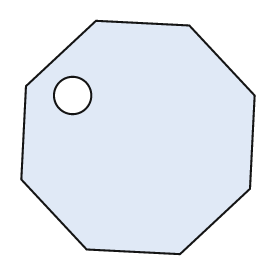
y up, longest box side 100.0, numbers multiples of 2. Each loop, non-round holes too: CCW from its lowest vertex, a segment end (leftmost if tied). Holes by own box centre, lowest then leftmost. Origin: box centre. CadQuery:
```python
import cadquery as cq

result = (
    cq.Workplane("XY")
    .moveTo(18.0, -50.0)
    .lineTo(48.0, -22.0)
    .lineTo(50.0, 18.0)
    .lineTo(22.0, 48.0)
    .lineTo(-18.0, 50.0)
    .lineTo(-48.0, 22.0)
    .lineTo(-50.0, -18.0)
    .lineTo(-22.0, -48.0)
    .close()
    .moveTo(-28.0, 18.0)
    .circle(8.0)
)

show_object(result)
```